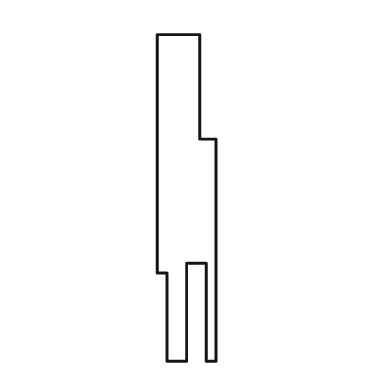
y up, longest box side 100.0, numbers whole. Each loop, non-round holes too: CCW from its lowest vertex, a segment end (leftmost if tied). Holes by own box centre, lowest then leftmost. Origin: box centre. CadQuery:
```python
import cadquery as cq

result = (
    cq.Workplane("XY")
    .moveTo(-6.0, -50.0)
    .lineTo(0.0, -50.0)
    .lineTo(0.0, -20.0)
    .lineTo(6.0, -20.0)
    .lineTo(6.0, -50.0)
    .lineTo(9.0, -50.0)
    .lineTo(9.0, 18.0)
    .lineTo(4.0, 18.0)
    .lineTo(4.0, 50.0)
    .lineTo(-9.0, 50.0)
    .lineTo(-9.0, -23.0)
    .lineTo(-6.0, -23.0)
    .close()
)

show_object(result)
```